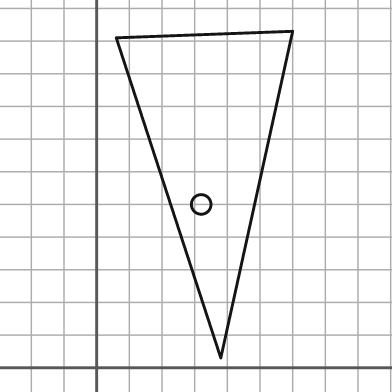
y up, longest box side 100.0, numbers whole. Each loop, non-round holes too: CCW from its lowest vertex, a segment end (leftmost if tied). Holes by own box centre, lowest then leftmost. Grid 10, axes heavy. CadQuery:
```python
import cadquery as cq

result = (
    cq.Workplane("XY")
    .moveTo(38.0, 3.0)
    .lineTo(60.0, 103.0)
    .lineTo(6.0, 101.0)
    .close()
    .moveTo(32.0, 50.0)
    .circle(3.0)
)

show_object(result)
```